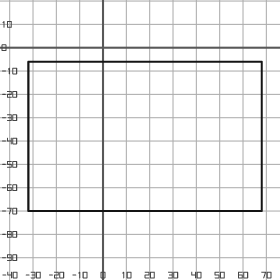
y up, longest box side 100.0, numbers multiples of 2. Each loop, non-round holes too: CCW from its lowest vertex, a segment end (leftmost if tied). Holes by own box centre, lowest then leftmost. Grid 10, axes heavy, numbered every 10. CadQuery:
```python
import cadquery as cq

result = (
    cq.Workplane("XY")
    .moveTo(-32.0, -70.0)
    .lineTo(68.0, -70.0)
    .lineTo(68.0, -6.0)
    .lineTo(-32.0, -6.0)
    .close()
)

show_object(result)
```